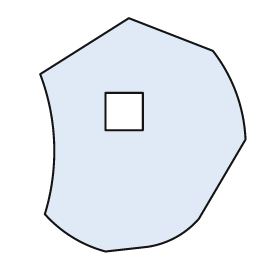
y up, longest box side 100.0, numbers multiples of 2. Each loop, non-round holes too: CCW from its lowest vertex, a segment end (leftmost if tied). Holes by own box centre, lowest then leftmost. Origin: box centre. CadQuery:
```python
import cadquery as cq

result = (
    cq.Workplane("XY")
    .moveTo(-16.0, -50.0)
    .lineTo(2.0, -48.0)
    .threePointArc((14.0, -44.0), (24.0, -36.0))
    .lineTo(44.0, -2.0)
    .threePointArc((40.0, 18.0), (30.0, 36.0))
    .lineTo(-6.0, 50.0)
    .lineTo(-44.0, 26.0)
    .threePointArc((-38.0, -4.0), (-42.0, -34.0))
    .threePointArc((-30.0, -44.0), (-16.0, -50.0))
    .close()
    .moveTo(-16.0, 2.0)
    .lineTo(0.0, 2.0)
    .lineTo(0.0, 18.0)
    .lineTo(-16.0, 18.0)
    .close()
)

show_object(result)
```